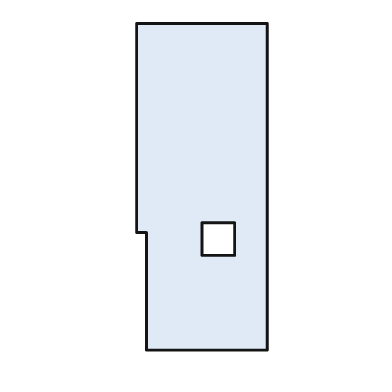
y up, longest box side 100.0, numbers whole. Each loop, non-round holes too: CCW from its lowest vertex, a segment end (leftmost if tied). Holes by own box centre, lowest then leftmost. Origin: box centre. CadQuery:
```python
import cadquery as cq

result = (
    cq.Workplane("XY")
    .moveTo(-17.0, -50.0)
    .lineTo(20.0, -50.0)
    .lineTo(20.0, 50.0)
    .lineTo(-20.0, 50.0)
    .lineTo(-20.0, -14.0)
    .lineTo(-17.0, -14.0)
    .close()
    .moveTo(0.0, -21.0)
    .lineTo(10.0, -21.0)
    .lineTo(10.0, -11.0)
    .lineTo(0.0, -11.0)
    .close()
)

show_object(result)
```